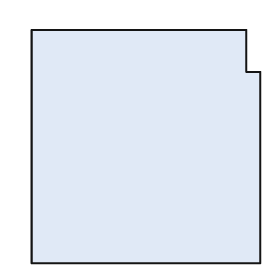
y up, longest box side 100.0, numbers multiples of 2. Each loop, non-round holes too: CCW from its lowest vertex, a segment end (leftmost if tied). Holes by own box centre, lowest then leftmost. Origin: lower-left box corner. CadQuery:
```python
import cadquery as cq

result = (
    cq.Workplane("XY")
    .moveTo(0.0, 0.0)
    .lineTo(98.0, 0.0)
    .lineTo(98.0, 82.0)
    .lineTo(92.0, 82.0)
    .lineTo(92.0, 100.0)
    .lineTo(0.0, 100.0)
    .close()
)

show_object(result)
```